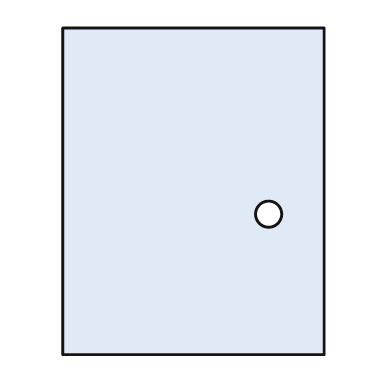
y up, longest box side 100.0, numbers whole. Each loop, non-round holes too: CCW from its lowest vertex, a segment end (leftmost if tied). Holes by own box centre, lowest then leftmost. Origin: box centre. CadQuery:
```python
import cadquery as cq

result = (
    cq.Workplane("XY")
    .moveTo(-40.0, -50.0)
    .lineTo(40.0, -50.0)
    .lineTo(40.0, 50.0)
    .lineTo(-40.0, 50.0)
    .close()
    .moveTo(23.0, -7.0)
    .circle(4.0)
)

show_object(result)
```